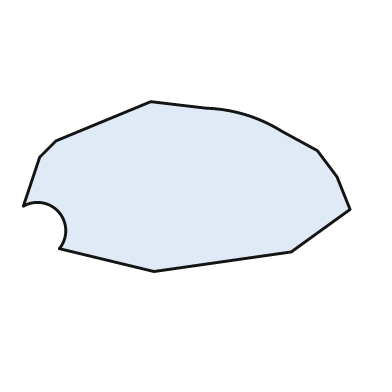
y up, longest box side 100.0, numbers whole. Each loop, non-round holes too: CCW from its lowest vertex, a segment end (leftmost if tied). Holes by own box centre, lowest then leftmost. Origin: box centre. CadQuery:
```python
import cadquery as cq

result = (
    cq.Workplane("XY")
    .moveTo(-10.0, -26.0)
    .lineTo(32.0, -20.0)
    .lineTo(50.0, -7.0)
    .lineTo(46.0, 3.0)
    .lineTo(40.0, 11.0)
    .lineTo(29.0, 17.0)
    .threePointArc((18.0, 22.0), (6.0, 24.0))
    .lineTo(-11.0, 26.0)
    .lineTo(-40.0, 14.0)
    .lineTo(-45.0, 9.0)
    .lineTo(-50.0, -6.0)
    .threePointArc((-39.0, -8.0), (-39.0, -19.0))
    .close()
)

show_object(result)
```